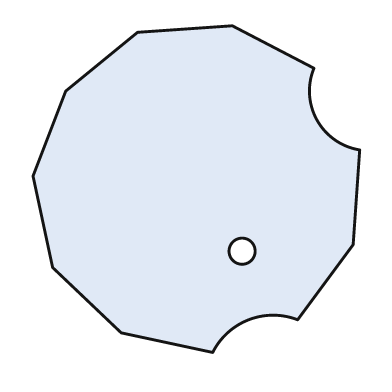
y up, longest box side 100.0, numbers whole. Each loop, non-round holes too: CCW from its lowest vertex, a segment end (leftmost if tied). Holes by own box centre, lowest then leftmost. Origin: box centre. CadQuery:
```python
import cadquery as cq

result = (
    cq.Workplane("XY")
    .moveTo(5.0, -50.0)
    .threePointArc((16.0, -40.0), (31.0, -40.0))
    .lineTo(48.0, -17.0)
    .lineTo(50.0, 12.0)
    .threePointArc((37.0, 21.0), (36.0, 37.0))
    .lineTo(11.0, 50.0)
    .lineTo(-18.0, 48.0)
    .lineTo(-40.0, 30.0)
    .lineTo(-50.0, 4.0)
    .lineTo(-44.0, -24.0)
    .lineTo(-23.0, -44.0)
    .close()
    .moveTo(14.0, -19.0)
    .circle(4.0)
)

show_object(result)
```